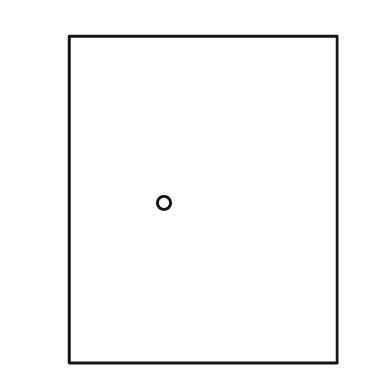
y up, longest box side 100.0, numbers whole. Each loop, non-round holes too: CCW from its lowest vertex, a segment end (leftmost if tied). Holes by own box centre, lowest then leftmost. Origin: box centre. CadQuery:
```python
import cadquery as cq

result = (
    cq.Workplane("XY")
    .moveTo(-41.0, -50.0)
    .lineTo(41.0, -50.0)
    .lineTo(41.0, 50.0)
    .lineTo(-41.0, 50.0)
    .close()
    .moveTo(-12.0, -1.0)
    .circle(2.0)
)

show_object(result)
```